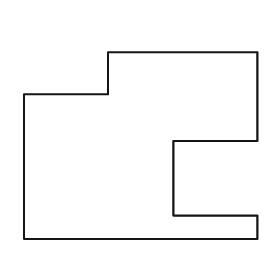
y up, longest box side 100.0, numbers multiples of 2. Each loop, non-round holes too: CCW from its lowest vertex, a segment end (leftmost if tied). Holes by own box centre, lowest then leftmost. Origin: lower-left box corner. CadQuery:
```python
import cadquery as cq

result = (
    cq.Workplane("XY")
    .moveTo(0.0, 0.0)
    .lineTo(100.0, 0.0)
    .lineTo(100.0, 10.0)
    .lineTo(64.0, 10.0)
    .lineTo(64.0, 42.0)
    .lineTo(100.0, 42.0)
    .lineTo(100.0, 80.0)
    .lineTo(36.0, 80.0)
    .lineTo(36.0, 62.0)
    .lineTo(0.0, 62.0)
    .close()
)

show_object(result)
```